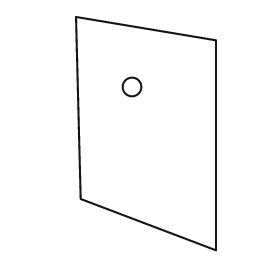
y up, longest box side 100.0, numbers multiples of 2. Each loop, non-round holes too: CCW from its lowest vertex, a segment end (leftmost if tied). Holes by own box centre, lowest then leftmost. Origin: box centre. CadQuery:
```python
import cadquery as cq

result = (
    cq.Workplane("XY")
    .moveTo(30.0, -50.0)
    .lineTo(30.0, 40.0)
    .lineTo(-30.0, 50.0)
    .lineTo(-28.0, -28.0)
    .close()
    .moveTo(-6.0, 20.0)
    .circle(4.0)
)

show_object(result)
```